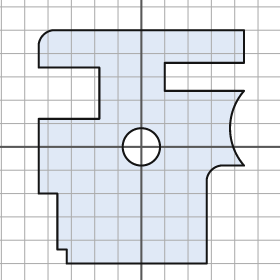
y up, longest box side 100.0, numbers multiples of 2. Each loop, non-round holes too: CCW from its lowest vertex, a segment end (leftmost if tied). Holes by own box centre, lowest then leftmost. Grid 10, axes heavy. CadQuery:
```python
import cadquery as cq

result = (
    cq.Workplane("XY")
    .moveTo(-32.0, -50.0)
    .lineTo(28.0, -50.0)
    .lineTo(28.0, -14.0)
    .threePointArc((30.0, -10.0), (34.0, -8.0))
    .lineTo(44.0, -8.0)
    .threePointArc((38.0, 8.0), (44.0, 24.0))
    .lineTo(10.0, 24.0)
    .lineTo(10.0, 36.0)
    .lineTo(44.0, 36.0)
    .lineTo(44.0, 50.0)
    .lineTo(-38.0, 50.0)
    .threePointArc((-42.0, 48.0), (-44.0, 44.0))
    .lineTo(-44.0, 34.0)
    .lineTo(-18.0, 34.0)
    .lineTo(-18.0, 12.0)
    .lineTo(-44.0, 12.0)
    .lineTo(-44.0, -20.0)
    .lineTo(-36.0, -20.0)
    .lineTo(-36.0, -44.0)
    .lineTo(-32.0, -44.0)
    .close()
    .moveTo(0.0, 0.0)
    .circle(8.0)
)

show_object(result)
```